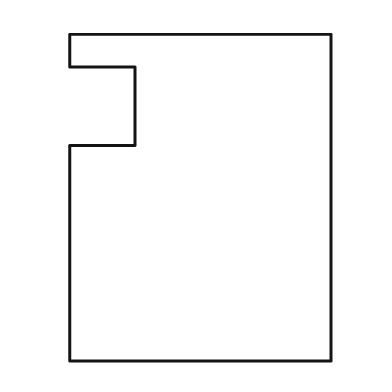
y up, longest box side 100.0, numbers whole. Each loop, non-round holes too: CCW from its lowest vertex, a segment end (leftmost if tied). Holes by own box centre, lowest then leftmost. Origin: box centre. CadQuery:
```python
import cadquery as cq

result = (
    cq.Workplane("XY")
    .moveTo(-40.0, -50.0)
    .lineTo(40.0, -50.0)
    .lineTo(40.0, 50.0)
    .lineTo(-40.0, 50.0)
    .lineTo(-40.0, 40.0)
    .lineTo(-20.0, 40.0)
    .lineTo(-20.0, 16.0)
    .lineTo(-40.0, 16.0)
    .close()
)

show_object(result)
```